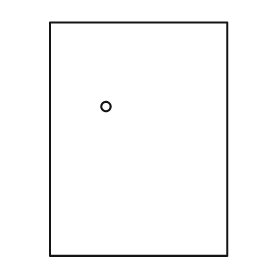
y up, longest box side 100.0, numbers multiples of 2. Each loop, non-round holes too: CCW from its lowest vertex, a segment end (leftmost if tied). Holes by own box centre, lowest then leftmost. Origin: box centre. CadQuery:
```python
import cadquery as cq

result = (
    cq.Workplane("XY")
    .moveTo(-38.0, -50.0)
    .lineTo(38.0, -50.0)
    .lineTo(38.0, 50.0)
    .lineTo(-38.0, 50.0)
    .close()
    .moveTo(-14.0, 14.0)
    .circle(2.0)
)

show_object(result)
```